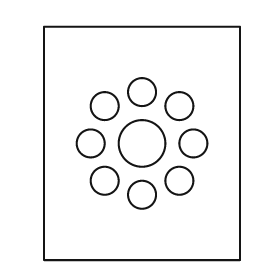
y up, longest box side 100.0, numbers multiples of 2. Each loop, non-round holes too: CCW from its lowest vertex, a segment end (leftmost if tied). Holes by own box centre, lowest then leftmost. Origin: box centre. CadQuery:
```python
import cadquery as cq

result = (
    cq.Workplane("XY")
    .moveTo(-42.0, -50.0)
    .lineTo(42.0, -50.0)
    .lineTo(42.0, 50.0)
    .lineTo(-42.0, 50.0)
    .close()
    .moveTo(0.0, -22.0)
    .circle(6.0)
    .moveTo(-16.0, -16.0)
    .circle(6.0)
    .moveTo(16.0, -16.0)
    .circle(6.0)
    .moveTo(-22.0, 0.0)
    .circle(6.0)
    .moveTo(0.0, 0.0)
    .circle(10.0)
    .moveTo(22.0, 0.0)
    .circle(6.0)
    .moveTo(-16.0, 16.0)
    .circle(6.0)
    .moveTo(16.0, 16.0)
    .circle(6.0)
    .moveTo(0.0, 22.0)
    .circle(6.0)
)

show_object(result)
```